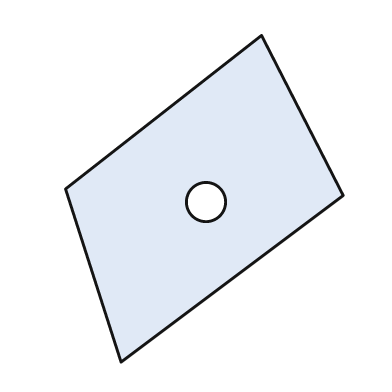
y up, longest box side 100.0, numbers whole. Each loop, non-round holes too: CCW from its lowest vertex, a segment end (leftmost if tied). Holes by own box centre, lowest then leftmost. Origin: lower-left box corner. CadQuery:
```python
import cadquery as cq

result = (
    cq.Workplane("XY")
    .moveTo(17.0, 0.0)
    .lineTo(85.0, 51.0)
    .lineTo(60.0, 100.0)
    .lineTo(0.0, 53.0)
    .close()
    .moveTo(43.0, 49.0)
    .circle(6.0)
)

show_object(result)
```